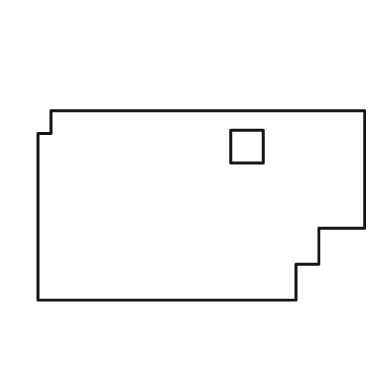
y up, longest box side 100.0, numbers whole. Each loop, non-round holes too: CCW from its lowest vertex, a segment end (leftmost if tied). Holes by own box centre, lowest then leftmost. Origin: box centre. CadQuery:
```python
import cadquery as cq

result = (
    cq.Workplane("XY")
    .moveTo(-50.0, -29.0)
    .lineTo(29.0, -29.0)
    .lineTo(29.0, -18.0)
    .lineTo(36.0, -18.0)
    .lineTo(36.0, -7.0)
    .lineTo(50.0, -7.0)
    .lineTo(50.0, 29.0)
    .lineTo(-46.0, 29.0)
    .lineTo(-46.0, 22.0)
    .lineTo(-50.0, 22.0)
    .close()
    .moveTo(9.0, 13.0)
    .lineTo(19.0, 13.0)
    .lineTo(19.0, 23.0)
    .lineTo(9.0, 23.0)
    .close()
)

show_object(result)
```